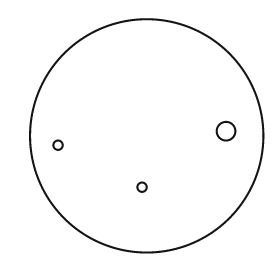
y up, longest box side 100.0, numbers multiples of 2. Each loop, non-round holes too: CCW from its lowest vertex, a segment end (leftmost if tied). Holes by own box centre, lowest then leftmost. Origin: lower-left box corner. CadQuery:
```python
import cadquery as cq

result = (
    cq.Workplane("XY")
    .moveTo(50.0, 50.0)
    .circle(50.0)
    .moveTo(48.0, 28.0)
    .circle(2.0)
    .moveTo(12.0, 46.0)
    .circle(2.0)
    .moveTo(84.0, 52.0)
    .circle(4.0)
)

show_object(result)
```